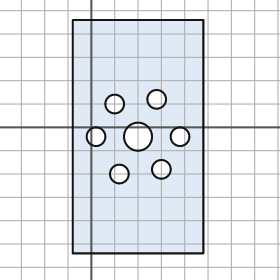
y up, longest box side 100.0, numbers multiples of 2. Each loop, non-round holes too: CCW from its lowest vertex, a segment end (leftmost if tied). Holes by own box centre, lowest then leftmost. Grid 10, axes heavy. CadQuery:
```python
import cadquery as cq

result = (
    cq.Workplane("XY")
    .moveTo(-8.0, -54.0)
    .lineTo(48.0, -54.0)
    .lineTo(48.0, 46.0)
    .lineTo(-8.0, 46.0)
    .close()
    .moveTo(12.0, -20.0)
    .circle(4.0)
    .moveTo(30.0, -18.0)
    .circle(4.0)
    .moveTo(2.0, -4.0)
    .circle(4.0)
    .moveTo(20.0, -4.0)
    .circle(6.0)
    .moveTo(38.0, -4.0)
    .circle(4.0)
    .moveTo(10.0, 10.0)
    .circle(4.0)
    .moveTo(28.0, 12.0)
    .circle(4.0)
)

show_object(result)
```